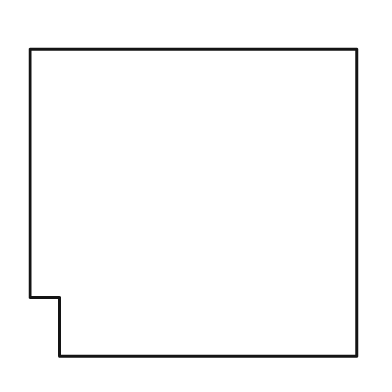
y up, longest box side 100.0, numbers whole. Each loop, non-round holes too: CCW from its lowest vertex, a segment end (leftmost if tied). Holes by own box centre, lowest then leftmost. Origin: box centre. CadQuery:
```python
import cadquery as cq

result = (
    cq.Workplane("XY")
    .moveTo(-41.0, -47.0)
    .lineTo(50.0, -47.0)
    .lineTo(50.0, 47.0)
    .lineTo(-50.0, 47.0)
    .lineTo(-50.0, -29.0)
    .lineTo(-41.0, -29.0)
    .close()
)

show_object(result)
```